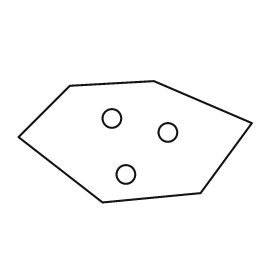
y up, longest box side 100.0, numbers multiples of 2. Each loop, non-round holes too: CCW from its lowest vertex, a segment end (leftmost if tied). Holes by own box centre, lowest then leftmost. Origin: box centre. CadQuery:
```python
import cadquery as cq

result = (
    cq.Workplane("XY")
    .moveTo(-14.0, -26.0)
    .lineTo(28.0, -22.0)
    .lineTo(50.0, 8.0)
    .lineTo(8.0, 26.0)
    .lineTo(-28.0, 24.0)
    .lineTo(-50.0, 2.0)
    .close()
    .moveTo(-4.0, -14.0)
    .circle(4.0)
    .moveTo(14.0, 4.0)
    .circle(4.0)
    .moveTo(-10.0, 10.0)
    .circle(4.0)
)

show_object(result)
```